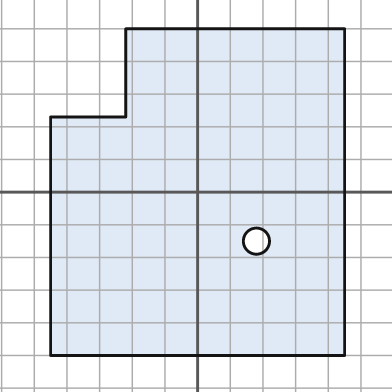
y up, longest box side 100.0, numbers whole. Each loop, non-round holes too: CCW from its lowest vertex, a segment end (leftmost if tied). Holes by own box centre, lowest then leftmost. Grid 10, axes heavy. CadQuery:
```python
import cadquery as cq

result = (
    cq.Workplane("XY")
    .moveTo(-45.0, -50.0)
    .lineTo(45.0, -50.0)
    .lineTo(45.0, 50.0)
    .lineTo(-22.0, 50.0)
    .lineTo(-22.0, 23.0)
    .lineTo(-45.0, 23.0)
    .close()
    .moveTo(18.0, -15.0)
    .circle(4.0)
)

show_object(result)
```